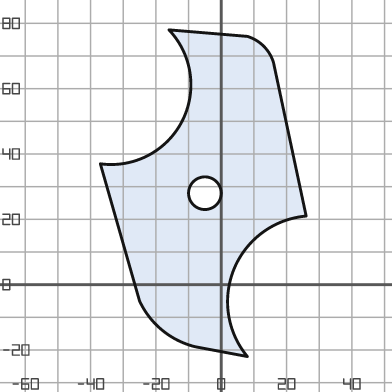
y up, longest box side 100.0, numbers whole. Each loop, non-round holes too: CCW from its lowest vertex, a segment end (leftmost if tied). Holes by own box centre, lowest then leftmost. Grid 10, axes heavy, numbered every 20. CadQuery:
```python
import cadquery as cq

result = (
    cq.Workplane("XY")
    .moveTo(8.0, -22.0)
    .threePointArc((4.0, 5.0), (26.0, 21.0))
    .lineTo(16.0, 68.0)
    .threePointArc((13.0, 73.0), (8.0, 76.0))
    .lineTo(-16.0, 78.0)
    .threePointArc((-12.0, 50.0), (-37.0, 37.0))
    .lineTo(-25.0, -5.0)
    .threePointArc((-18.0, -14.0), (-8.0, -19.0))
    .close()
    .moveTo(-5.0, 28.0)
    .circle(5.0)
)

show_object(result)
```